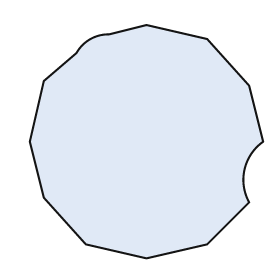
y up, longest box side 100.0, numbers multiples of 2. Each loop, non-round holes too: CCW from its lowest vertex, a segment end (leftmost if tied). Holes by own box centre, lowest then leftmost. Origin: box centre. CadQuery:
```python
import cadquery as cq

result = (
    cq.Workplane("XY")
    .moveTo(0.0, -50.0)
    .lineTo(26.0, -44.0)
    .lineTo(44.0, -26.0)
    .threePointArc((42.0, -12.0), (50.0, 0.0))
    .lineTo(44.0, 24.0)
    .lineTo(26.0, 44.0)
    .lineTo(0.0, 50.0)
    .lineTo(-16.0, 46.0)
    .threePointArc((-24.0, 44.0), (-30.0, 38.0))
    .lineTo(-44.0, 26.0)
    .lineTo(-50.0, 0.0)
    .lineTo(-44.0, -24.0)
    .lineTo(-26.0, -44.0)
    .close()
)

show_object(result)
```